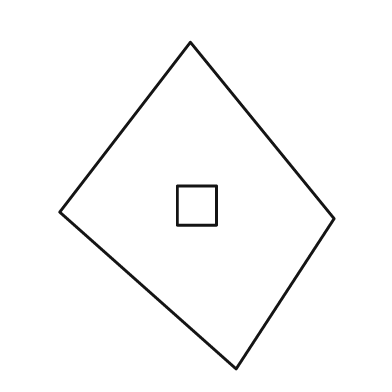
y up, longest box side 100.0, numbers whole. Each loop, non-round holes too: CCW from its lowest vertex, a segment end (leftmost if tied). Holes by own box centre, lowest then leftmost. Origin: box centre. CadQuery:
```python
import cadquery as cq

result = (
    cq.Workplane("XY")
    .moveTo(12.0, -50.0)
    .lineTo(42.0, -4.0)
    .lineTo(-2.0, 50.0)
    .lineTo(-42.0, -2.0)
    .close()
    .moveTo(-6.0, -6.0)
    .lineTo(6.0, -6.0)
    .lineTo(6.0, 6.0)
    .lineTo(-6.0, 6.0)
    .close()
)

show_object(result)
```